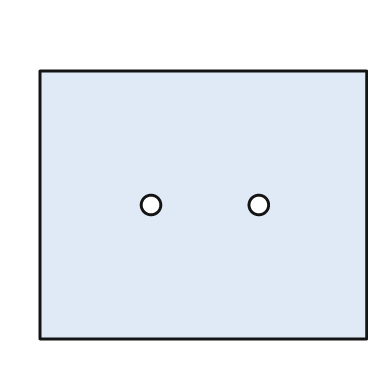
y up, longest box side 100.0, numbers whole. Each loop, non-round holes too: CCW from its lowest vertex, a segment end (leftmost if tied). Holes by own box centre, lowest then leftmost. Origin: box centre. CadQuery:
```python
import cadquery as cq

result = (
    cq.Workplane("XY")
    .moveTo(-50.0, -41.0)
    .lineTo(50.0, -41.0)
    .lineTo(50.0, 41.0)
    .lineTo(-50.0, 41.0)
    .close()
    .moveTo(-16.0, 0.0)
    .circle(3.0)
    .moveTo(17.0, 0.0)
    .circle(3.0)
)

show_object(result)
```